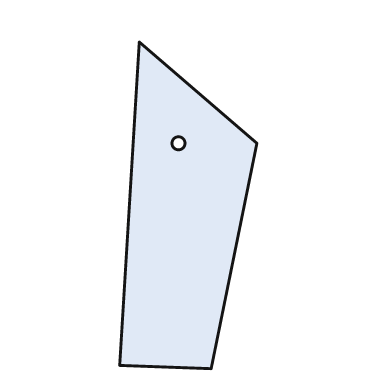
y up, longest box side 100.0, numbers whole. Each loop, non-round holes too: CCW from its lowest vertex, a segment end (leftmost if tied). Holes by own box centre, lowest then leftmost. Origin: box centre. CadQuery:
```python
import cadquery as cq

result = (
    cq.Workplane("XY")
    .moveTo(7.0, -50.0)
    .lineTo(21.0, 19.0)
    .lineTo(-15.0, 50.0)
    .lineTo(-21.0, -49.0)
    .close()
    .moveTo(-3.0, 19.0)
    .circle(2.0)
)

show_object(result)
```